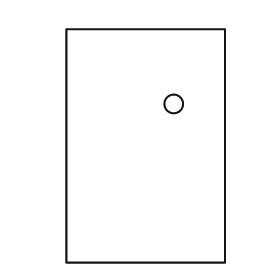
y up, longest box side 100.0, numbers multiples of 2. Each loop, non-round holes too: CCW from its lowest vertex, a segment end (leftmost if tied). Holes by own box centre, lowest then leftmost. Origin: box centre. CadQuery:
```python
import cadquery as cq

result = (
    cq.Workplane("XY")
    .moveTo(-34.0, -50.0)
    .lineTo(34.0, -50.0)
    .lineTo(34.0, 50.0)
    .lineTo(-34.0, 50.0)
    .close()
    .moveTo(12.0, 18.0)
    .circle(4.0)
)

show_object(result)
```